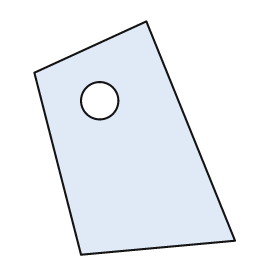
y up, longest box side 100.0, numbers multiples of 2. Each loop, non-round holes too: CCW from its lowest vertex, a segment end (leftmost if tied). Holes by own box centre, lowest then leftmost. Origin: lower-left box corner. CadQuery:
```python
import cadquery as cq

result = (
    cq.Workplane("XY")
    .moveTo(20.0, 0.0)
    .lineTo(86.0, 6.0)
    .lineTo(48.0, 100.0)
    .lineTo(0.0, 78.0)
    .close()
    .moveTo(28.0, 66.0)
    .circle(8.0)
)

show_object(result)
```